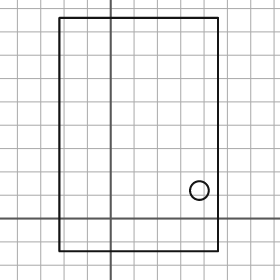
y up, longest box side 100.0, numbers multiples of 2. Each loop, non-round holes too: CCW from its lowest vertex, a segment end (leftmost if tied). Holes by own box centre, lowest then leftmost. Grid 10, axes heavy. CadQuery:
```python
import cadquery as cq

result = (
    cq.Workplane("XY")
    .moveTo(-22.0, -14.0)
    .lineTo(46.0, -14.0)
    .lineTo(46.0, 86.0)
    .lineTo(-22.0, 86.0)
    .close()
    .moveTo(38.0, 12.0)
    .circle(4.0)
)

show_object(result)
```